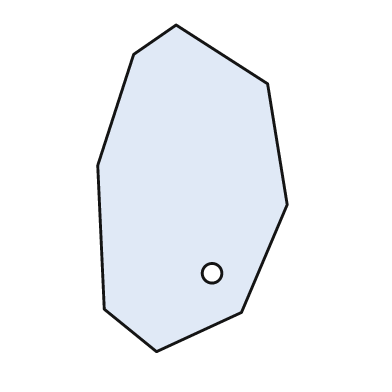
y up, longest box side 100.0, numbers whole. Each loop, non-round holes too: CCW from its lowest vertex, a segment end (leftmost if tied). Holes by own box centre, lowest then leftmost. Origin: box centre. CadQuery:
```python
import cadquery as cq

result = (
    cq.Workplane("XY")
    .moveTo(-11.0, -50.0)
    .lineTo(15.0, -38.0)
    .lineTo(29.0, -5.0)
    .lineTo(23.0, 32.0)
    .lineTo(-5.0, 50.0)
    .lineTo(-18.0, 41.0)
    .lineTo(-29.0, 7.0)
    .lineTo(-27.0, -37.0)
    .close()
    .moveTo(6.0, -26.0)
    .circle(3.0)
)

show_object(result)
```